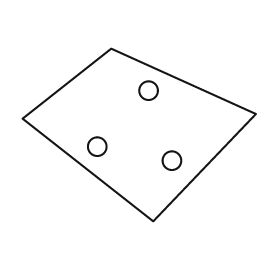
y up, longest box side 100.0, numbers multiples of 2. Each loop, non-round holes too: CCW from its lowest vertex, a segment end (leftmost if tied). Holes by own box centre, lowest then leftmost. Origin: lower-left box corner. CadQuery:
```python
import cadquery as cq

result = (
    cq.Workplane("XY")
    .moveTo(56.0, 0.0)
    .lineTo(100.0, 46.0)
    .lineTo(38.0, 74.0)
    .lineTo(0.0, 44.0)
    .close()
    .moveTo(64.0, 26.0)
    .circle(4.0)
    .moveTo(32.0, 32.0)
    .circle(4.0)
    .moveTo(54.0, 56.0)
    .circle(4.0)
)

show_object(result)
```